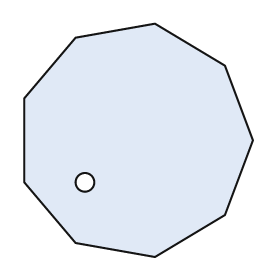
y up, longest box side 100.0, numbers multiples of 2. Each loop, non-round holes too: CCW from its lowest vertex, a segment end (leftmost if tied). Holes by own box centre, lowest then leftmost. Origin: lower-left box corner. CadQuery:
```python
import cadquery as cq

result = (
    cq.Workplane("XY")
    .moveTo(56.0, 0.0)
    .lineTo(86.0, 18.0)
    .lineTo(98.0, 50.0)
    .lineTo(86.0, 82.0)
    .lineTo(56.0, 100.0)
    .lineTo(22.0, 94.0)
    .lineTo(0.0, 68.0)
    .lineTo(0.0, 32.0)
    .lineTo(22.0, 6.0)
    .close()
    .moveTo(26.0, 32.0)
    .circle(4.0)
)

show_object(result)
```